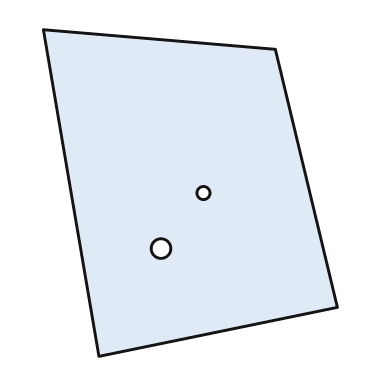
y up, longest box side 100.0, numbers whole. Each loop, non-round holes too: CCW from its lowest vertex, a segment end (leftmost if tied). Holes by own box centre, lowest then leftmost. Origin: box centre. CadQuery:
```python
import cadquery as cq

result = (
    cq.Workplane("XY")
    .moveTo(-28.0, -50.0)
    .lineTo(45.0, -35.0)
    .lineTo(26.0, 44.0)
    .lineTo(-45.0, 50.0)
    .close()
    .moveTo(-9.0, -17.0)
    .circle(3.0)
    .moveTo(4.0, 0.0)
    .circle(2.0)
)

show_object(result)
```